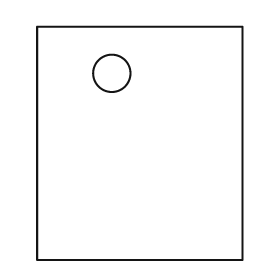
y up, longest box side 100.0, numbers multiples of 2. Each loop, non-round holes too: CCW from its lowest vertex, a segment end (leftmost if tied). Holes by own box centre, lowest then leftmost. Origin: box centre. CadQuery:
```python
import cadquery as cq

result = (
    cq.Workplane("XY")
    .moveTo(-44.0, -50.0)
    .lineTo(44.0, -50.0)
    .lineTo(44.0, 50.0)
    .lineTo(-44.0, 50.0)
    .close()
    .moveTo(-12.0, 30.0)
    .circle(8.0)
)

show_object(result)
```